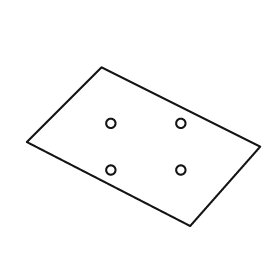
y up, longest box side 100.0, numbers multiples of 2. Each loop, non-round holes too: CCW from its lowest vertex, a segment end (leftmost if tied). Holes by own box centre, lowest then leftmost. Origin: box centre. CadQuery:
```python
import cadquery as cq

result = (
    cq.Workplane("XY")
    .moveTo(20.0, -34.0)
    .lineTo(50.0, 0.0)
    .lineTo(-18.0, 34.0)
    .lineTo(-50.0, 2.0)
    .close()
    .moveTo(-14.0, -10.0)
    .circle(2.0)
    .moveTo(16.0, -10.0)
    .circle(2.0)
    .moveTo(-14.0, 10.0)
    .circle(2.0)
    .moveTo(16.0, 10.0)
    .circle(2.0)
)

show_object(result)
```